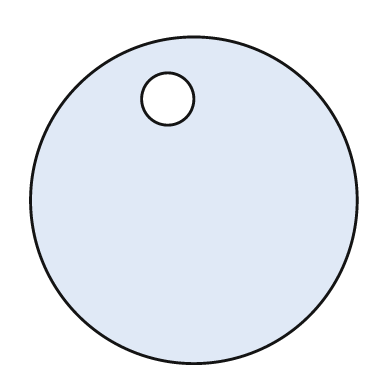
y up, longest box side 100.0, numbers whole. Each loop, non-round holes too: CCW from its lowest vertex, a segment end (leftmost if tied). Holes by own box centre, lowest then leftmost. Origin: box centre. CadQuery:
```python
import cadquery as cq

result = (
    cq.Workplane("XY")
    .moveTo(0.0, 0.0)
    .circle(50.0)
    .moveTo(-8.0, 31.0)
    .circle(8.0)
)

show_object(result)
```